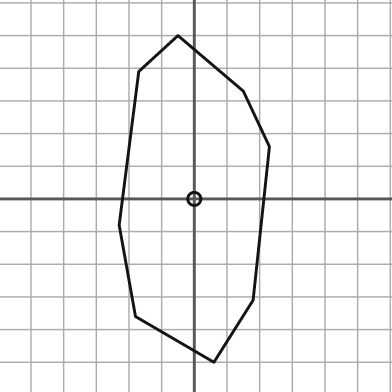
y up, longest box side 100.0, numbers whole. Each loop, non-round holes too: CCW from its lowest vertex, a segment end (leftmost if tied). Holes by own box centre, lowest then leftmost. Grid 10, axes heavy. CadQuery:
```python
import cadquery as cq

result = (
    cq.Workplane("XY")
    .moveTo(6.0, -50.0)
    .lineTo(18.0, -31.0)
    .lineTo(23.0, 16.0)
    .lineTo(15.0, 33.0)
    .lineTo(-5.0, 50.0)
    .lineTo(-17.0, 39.0)
    .lineTo(-23.0, -8.0)
    .lineTo(-18.0, -36.0)
    .close()
    .moveTo(0.0, 0.0)
    .circle(2.0)
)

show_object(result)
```